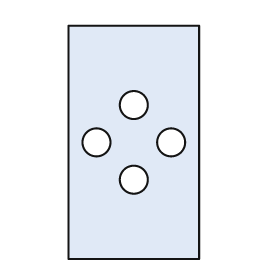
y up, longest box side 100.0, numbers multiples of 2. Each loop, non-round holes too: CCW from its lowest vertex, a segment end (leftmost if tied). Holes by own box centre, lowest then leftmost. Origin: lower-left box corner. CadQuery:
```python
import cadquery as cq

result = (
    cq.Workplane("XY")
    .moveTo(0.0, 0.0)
    .lineTo(56.0, 0.0)
    .lineTo(56.0, 100.0)
    .lineTo(0.0, 100.0)
    .close()
    .moveTo(28.0, 34.0)
    .circle(6.0)
    .moveTo(12.0, 50.0)
    .circle(6.0)
    .moveTo(44.0, 50.0)
    .circle(6.0)
    .moveTo(28.0, 66.0)
    .circle(6.0)
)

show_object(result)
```